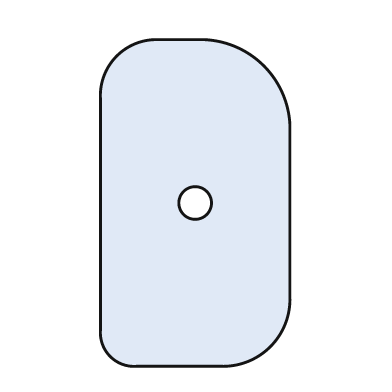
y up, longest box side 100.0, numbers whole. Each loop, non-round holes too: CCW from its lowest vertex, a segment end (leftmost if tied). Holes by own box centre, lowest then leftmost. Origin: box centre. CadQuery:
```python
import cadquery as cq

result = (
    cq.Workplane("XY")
    .moveTo(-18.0, -50.0)
    .lineTo(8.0, -50.0)
    .threePointArc((23.0, -44.0), (29.0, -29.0))
    .lineTo(29.0, 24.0)
    .threePointArc((21.0, 42.0), (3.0, 50.0))
    .lineTo(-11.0, 50.0)
    .threePointArc((-24.0, 45.0), (-29.0, 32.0))
    .lineTo(-29.0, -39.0)
    .threePointArc((-26.0, -47.0), (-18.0, -50.0))
    .close()
    .moveTo(0.0, 0.0)
    .circle(5.0)
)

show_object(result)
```